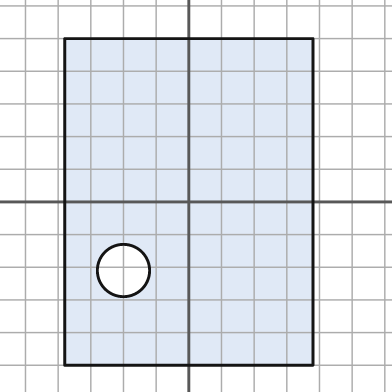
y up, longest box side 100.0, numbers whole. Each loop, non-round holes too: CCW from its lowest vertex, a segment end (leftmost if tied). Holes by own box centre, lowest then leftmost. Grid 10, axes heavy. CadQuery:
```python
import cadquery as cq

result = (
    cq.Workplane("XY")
    .moveTo(-38.0, -50.0)
    .lineTo(38.0, -50.0)
    .lineTo(38.0, 50.0)
    .lineTo(-38.0, 50.0)
    .close()
    .moveTo(-20.0, -21.0)
    .circle(8.0)
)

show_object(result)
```